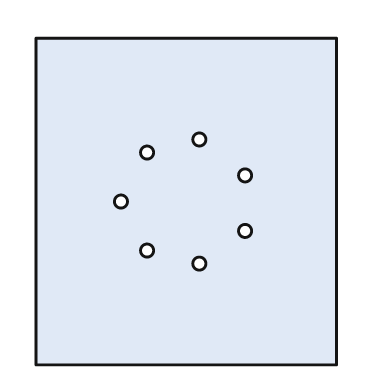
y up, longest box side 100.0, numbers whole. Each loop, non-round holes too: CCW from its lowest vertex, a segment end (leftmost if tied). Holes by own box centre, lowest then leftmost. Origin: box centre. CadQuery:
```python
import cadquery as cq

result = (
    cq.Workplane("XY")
    .moveTo(-46.0, -50.0)
    .lineTo(46.0, -50.0)
    .lineTo(46.0, 50.0)
    .lineTo(-46.0, 50.0)
    .close()
    .moveTo(4.0, -19.0)
    .circle(2.0)
    .moveTo(-12.0, -15.0)
    .circle(2.0)
    .moveTo(18.0, -9.0)
    .circle(2.0)
    .moveTo(-20.0, 0.0)
    .circle(2.0)
    .moveTo(18.0, 8.0)
    .circle(2.0)
    .moveTo(-12.0, 15.0)
    .circle(2.0)
    .moveTo(4.0, 19.0)
    .circle(2.0)
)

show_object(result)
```